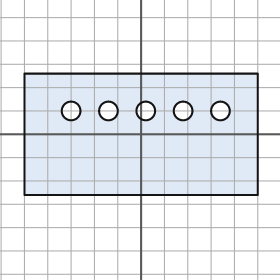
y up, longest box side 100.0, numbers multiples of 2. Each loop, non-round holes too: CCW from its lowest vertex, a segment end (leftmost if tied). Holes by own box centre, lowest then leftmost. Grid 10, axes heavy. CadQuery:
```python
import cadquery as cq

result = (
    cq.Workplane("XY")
    .moveTo(-50.0, -26.0)
    .lineTo(50.0, -26.0)
    .lineTo(50.0, 26.0)
    .lineTo(-50.0, 26.0)
    .close()
    .moveTo(-30.0, 10.0)
    .circle(4.0)
    .moveTo(-14.0, 10.0)
    .circle(4.0)
    .moveTo(2.0, 10.0)
    .circle(4.0)
    .moveTo(18.0, 10.0)
    .circle(4.0)
    .moveTo(34.0, 10.0)
    .circle(4.0)
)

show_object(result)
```